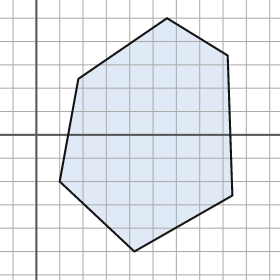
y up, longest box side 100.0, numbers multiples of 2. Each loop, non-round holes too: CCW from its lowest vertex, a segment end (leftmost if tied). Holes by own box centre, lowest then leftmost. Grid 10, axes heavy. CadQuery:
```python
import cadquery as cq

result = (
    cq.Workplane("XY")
    .moveTo(42.0, -50.0)
    .lineTo(84.0, -26.0)
    .lineTo(82.0, 34.0)
    .lineTo(56.0, 50.0)
    .lineTo(18.0, 24.0)
    .lineTo(10.0, -20.0)
    .close()
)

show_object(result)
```